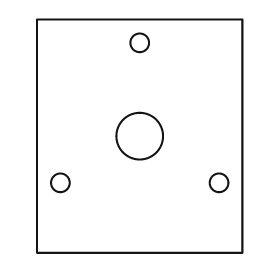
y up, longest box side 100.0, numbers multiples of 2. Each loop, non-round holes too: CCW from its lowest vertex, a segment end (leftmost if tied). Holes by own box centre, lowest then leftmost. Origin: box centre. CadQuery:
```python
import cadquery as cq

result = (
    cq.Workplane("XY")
    .moveTo(-44.0, -50.0)
    .lineTo(44.0, -50.0)
    .lineTo(44.0, 50.0)
    .lineTo(-44.0, 50.0)
    .close()
    .moveTo(-34.0, -20.0)
    .circle(4.0)
    .moveTo(34.0, -20.0)
    .circle(4.0)
    .moveTo(0.0, 0.0)
    .circle(10.0)
    .moveTo(0.0, 40.0)
    .circle(4.0)
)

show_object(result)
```